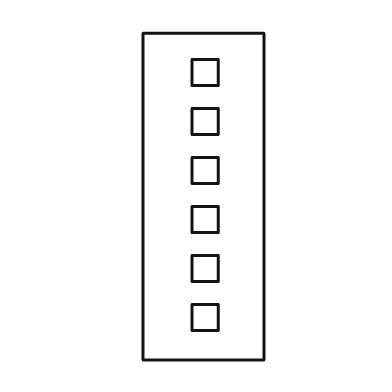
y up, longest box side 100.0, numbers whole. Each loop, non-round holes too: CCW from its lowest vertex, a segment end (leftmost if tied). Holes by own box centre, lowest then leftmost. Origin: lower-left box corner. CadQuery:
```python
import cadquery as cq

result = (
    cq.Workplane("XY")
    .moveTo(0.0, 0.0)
    .lineTo(37.0, 0.0)
    .lineTo(37.0, 100.0)
    .lineTo(0.0, 100.0)
    .close()
    .moveTo(15.0, 9.0)
    .lineTo(23.0, 9.0)
    .lineTo(23.0, 17.0)
    .lineTo(15.0, 17.0)
    .close()
    .moveTo(15.0, 24.0)
    .lineTo(23.0, 24.0)
    .lineTo(23.0, 32.0)
    .lineTo(15.0, 32.0)
    .close()
    .moveTo(15.0, 39.0)
    .lineTo(23.0, 39.0)
    .lineTo(23.0, 47.0)
    .lineTo(15.0, 47.0)
    .close()
    .moveTo(15.0, 54.0)
    .lineTo(23.0, 54.0)
    .lineTo(23.0, 62.0)
    .lineTo(15.0, 62.0)
    .close()
    .moveTo(15.0, 69.0)
    .lineTo(23.0, 69.0)
    .lineTo(23.0, 77.0)
    .lineTo(15.0, 77.0)
    .close()
    .moveTo(15.0, 84.0)
    .lineTo(23.0, 84.0)
    .lineTo(23.0, 92.0)
    .lineTo(15.0, 92.0)
    .close()
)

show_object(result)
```